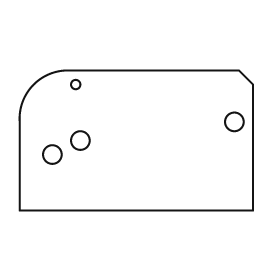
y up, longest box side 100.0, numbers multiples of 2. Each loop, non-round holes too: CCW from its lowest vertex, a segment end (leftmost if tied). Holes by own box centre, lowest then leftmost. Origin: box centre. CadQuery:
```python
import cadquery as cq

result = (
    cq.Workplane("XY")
    .moveTo(-50.0, -30.0)
    .lineTo(50.0, -30.0)
    .lineTo(50.0, 24.0)
    .lineTo(44.0, 30.0)
    .lineTo(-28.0, 30.0)
    .threePointArc((-44.0, 24.0), (-50.0, 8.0))
    .close()
    .moveTo(-36.0, -6.0)
    .circle(4.0)
    .moveTo(-24.0, 0.0)
    .circle(4.0)
    .moveTo(42.0, 8.0)
    .circle(4.0)
    .moveTo(-26.0, 24.0)
    .circle(2.0)
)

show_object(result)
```